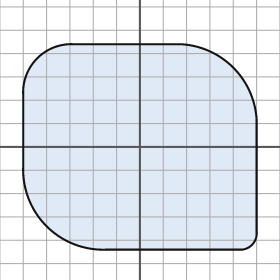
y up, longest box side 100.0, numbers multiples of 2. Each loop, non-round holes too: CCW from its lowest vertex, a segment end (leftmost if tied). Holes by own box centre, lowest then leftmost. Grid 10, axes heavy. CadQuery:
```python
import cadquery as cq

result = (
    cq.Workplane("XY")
    .moveTo(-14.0, -44.0)
    .lineTo(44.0, -44.0)
    .threePointArc((48.0, -42.0), (50.0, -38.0))
    .lineTo(50.0, 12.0)
    .threePointArc((40.0, 34.0), (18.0, 44.0))
    .lineTo(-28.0, 44.0)
    .threePointArc((-44.0, 38.0), (-50.0, 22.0))
    .lineTo(-50.0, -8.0)
    .threePointArc((-40.0, -34.0), (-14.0, -44.0))
    .close()
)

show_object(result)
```